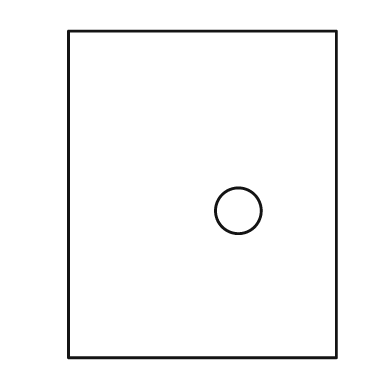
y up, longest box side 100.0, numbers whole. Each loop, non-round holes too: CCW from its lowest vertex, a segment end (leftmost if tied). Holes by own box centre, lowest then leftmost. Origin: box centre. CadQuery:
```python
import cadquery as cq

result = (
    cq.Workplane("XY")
    .moveTo(-41.0, -50.0)
    .lineTo(41.0, -50.0)
    .lineTo(41.0, 50.0)
    .lineTo(-41.0, 50.0)
    .close()
    .moveTo(11.0, -5.0)
    .circle(7.0)
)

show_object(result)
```